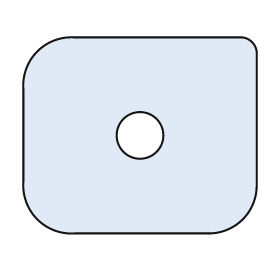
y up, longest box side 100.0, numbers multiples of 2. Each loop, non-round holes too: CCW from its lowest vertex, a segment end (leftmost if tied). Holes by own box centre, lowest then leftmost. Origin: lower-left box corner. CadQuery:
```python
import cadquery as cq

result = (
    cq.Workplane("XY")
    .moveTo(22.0, 0.0)
    .lineTo(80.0, 0.0)
    .threePointArc((94.0, 6.0), (100.0, 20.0))
    .lineTo(100.0, 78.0)
    .threePointArc((98.0, 82.0), (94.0, 84.0))
    .lineTo(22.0, 84.0)
    .threePointArc((6.0, 78.0), (0.0, 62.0))
    .lineTo(0.0, 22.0)
    .threePointArc((6.0, 6.0), (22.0, 0.0))
    .close()
    .moveTo(50.0, 42.0)
    .circle(10.0)
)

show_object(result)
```